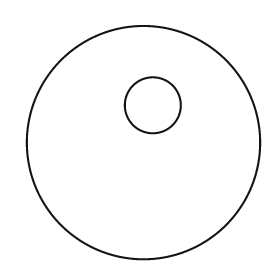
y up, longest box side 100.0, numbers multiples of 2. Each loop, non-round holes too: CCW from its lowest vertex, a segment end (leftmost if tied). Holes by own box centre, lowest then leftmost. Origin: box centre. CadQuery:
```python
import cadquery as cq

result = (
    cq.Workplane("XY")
    .moveTo(0.0, 0.0)
    .circle(50.0)
    .moveTo(4.0, 16.0)
    .circle(12.0)
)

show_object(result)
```